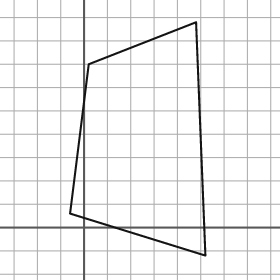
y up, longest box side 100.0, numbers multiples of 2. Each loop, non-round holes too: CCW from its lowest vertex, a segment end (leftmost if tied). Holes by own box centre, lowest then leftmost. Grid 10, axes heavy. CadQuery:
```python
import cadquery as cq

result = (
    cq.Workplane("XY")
    .moveTo(52.0, -12.0)
    .lineTo(48.0, 88.0)
    .lineTo(2.0, 70.0)
    .lineTo(-6.0, 6.0)
    .close()
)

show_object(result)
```